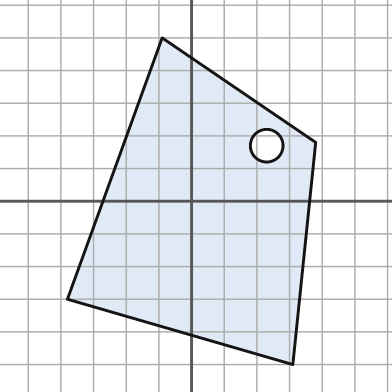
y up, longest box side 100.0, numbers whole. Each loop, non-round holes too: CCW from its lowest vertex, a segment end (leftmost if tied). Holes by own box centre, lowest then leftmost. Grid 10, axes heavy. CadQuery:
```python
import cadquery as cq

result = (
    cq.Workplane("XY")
    .moveTo(31.0, -50.0)
    .lineTo(38.0, 18.0)
    .lineTo(-9.0, 50.0)
    .lineTo(-38.0, -30.0)
    .close()
    .moveTo(23.0, 17.0)
    .circle(5.0)
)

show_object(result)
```